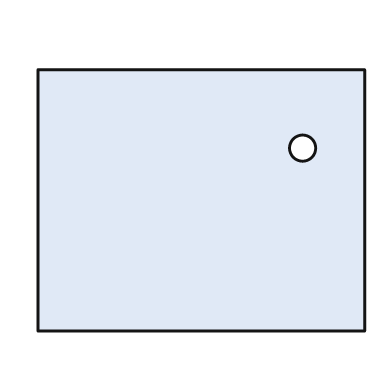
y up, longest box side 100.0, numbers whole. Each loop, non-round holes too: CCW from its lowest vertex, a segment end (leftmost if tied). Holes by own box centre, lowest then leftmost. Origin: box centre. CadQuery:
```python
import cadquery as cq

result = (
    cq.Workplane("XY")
    .moveTo(-50.0, -40.0)
    .lineTo(50.0, -40.0)
    .lineTo(50.0, 40.0)
    .lineTo(-50.0, 40.0)
    .close()
    .moveTo(31.0, 16.0)
    .circle(4.0)
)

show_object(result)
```